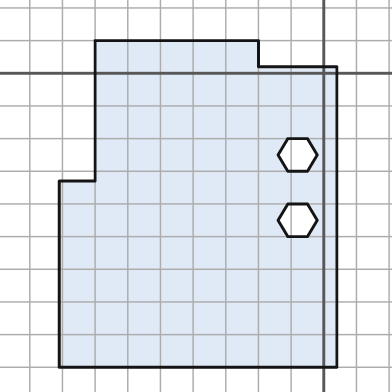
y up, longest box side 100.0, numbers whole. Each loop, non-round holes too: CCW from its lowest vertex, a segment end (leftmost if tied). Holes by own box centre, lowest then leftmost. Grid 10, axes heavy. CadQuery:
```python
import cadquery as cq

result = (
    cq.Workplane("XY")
    .moveTo(-81.0, -90.0)
    .lineTo(4.0, -90.0)
    .lineTo(4.0, 2.0)
    .lineTo(-20.0, 2.0)
    .lineTo(-20.0, 10.0)
    .lineTo(-70.0, 10.0)
    .lineTo(-70.0, -33.0)
    .lineTo(-81.0, -33.0)
    .close()
    .moveTo(-11.0, -50.0)
    .lineTo(-5.0, -50.0)
    .lineTo(-2.0, -45.0)
    .lineTo(-5.0, -40.0)
    .lineTo(-11.0, -40.0)
    .lineTo(-14.0, -45.0)
    .close()
    .moveTo(-11.0, -30.0)
    .lineTo(-5.0, -30.0)
    .lineTo(-2.0, -25.0)
    .lineTo(-5.0, -20.0)
    .lineTo(-11.0, -20.0)
    .lineTo(-14.0, -25.0)
    .close()
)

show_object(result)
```